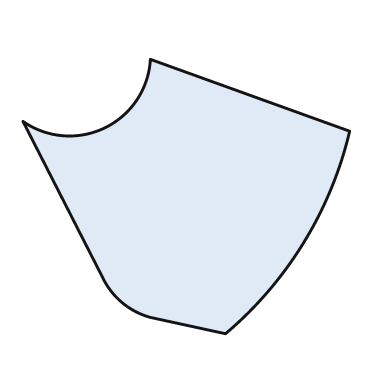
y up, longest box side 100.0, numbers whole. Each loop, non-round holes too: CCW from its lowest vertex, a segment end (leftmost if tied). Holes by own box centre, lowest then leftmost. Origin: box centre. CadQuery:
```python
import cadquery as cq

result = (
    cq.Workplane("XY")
    .moveTo(12.0, -42.0)
    .threePointArc((36.0, -14.0), (50.0, 20.0))
    .lineTo(-11.0, 42.0)
    .threePointArc((-25.0, 21.0), (-50.0, 23.0))
    .lineTo(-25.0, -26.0)
    .threePointArc((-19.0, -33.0), (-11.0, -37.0))
    .close()
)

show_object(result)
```